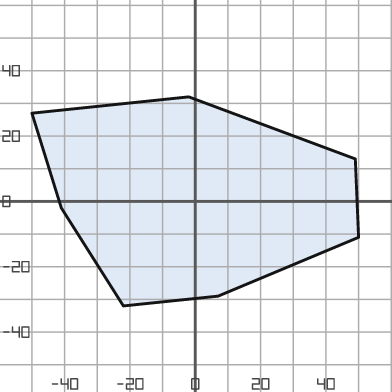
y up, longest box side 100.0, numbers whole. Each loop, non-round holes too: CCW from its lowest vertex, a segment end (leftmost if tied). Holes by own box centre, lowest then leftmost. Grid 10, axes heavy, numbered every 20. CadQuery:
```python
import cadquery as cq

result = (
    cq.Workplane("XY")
    .moveTo(-22.0, -32.0)
    .lineTo(7.0, -29.0)
    .lineTo(50.0, -11.0)
    .lineTo(49.0, 13.0)
    .lineTo(-2.0, 32.0)
    .lineTo(-50.0, 27.0)
    .lineTo(-41.0, -2.0)
    .close()
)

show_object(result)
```